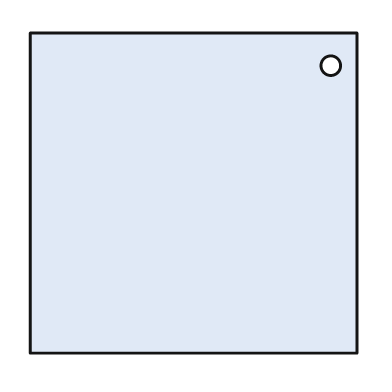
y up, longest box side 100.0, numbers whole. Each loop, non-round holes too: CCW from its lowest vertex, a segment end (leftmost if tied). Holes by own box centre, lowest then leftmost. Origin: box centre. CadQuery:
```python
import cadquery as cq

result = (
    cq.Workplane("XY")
    .moveTo(-50.0, -49.0)
    .lineTo(50.0, -49.0)
    .lineTo(50.0, 49.0)
    .lineTo(-50.0, 49.0)
    .close()
    .moveTo(42.0, 39.0)
    .circle(3.0)
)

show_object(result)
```